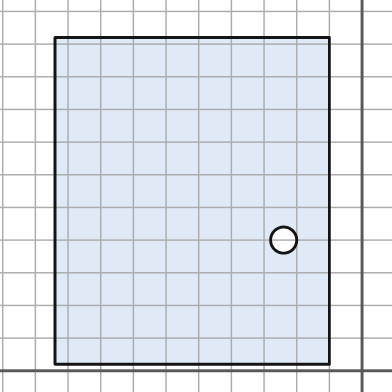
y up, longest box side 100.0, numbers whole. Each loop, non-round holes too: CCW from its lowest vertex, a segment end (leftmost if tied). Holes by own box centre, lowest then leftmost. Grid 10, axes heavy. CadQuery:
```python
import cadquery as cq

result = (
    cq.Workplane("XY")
    .moveTo(-94.0, 2.0)
    .lineTo(-10.0, 2.0)
    .lineTo(-10.0, 102.0)
    .lineTo(-94.0, 102.0)
    .close()
    .moveTo(-24.0, 40.0)
    .circle(4.0)
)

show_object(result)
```